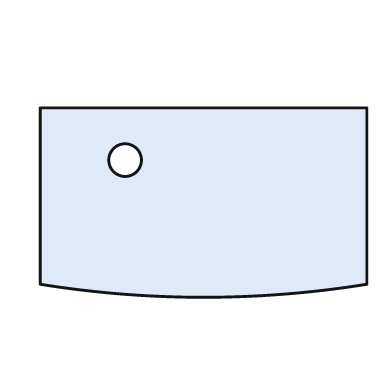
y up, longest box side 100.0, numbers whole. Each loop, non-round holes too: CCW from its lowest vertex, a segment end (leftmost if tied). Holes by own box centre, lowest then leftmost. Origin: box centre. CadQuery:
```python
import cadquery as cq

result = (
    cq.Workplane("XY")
    .moveTo(-50.0, -25.0)
    .threePointArc((0.0, -29.0), (50.0, -25.0))
    .lineTo(50.0, 29.0)
    .lineTo(-50.0, 29.0)
    .close()
    .moveTo(-24.0, 13.0)
    .circle(5.0)
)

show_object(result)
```